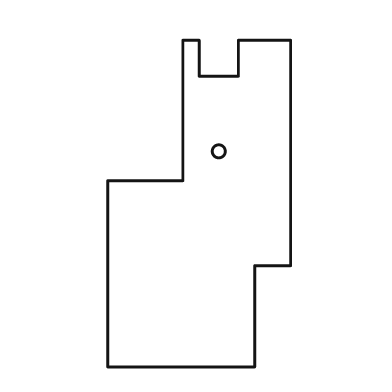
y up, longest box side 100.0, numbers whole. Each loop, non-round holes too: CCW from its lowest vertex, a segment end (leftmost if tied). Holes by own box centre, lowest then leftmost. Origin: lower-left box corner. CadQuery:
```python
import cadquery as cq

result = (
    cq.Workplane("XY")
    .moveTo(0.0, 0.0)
    .lineTo(45.0, 0.0)
    .lineTo(45.0, 31.0)
    .lineTo(56.0, 31.0)
    .lineTo(56.0, 100.0)
    .lineTo(40.0, 100.0)
    .lineTo(40.0, 89.0)
    .lineTo(28.0, 89.0)
    .lineTo(28.0, 100.0)
    .lineTo(23.0, 100.0)
    .lineTo(23.0, 57.0)
    .lineTo(0.0, 57.0)
    .close()
    .moveTo(34.0, 66.0)
    .circle(2.0)
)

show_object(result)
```